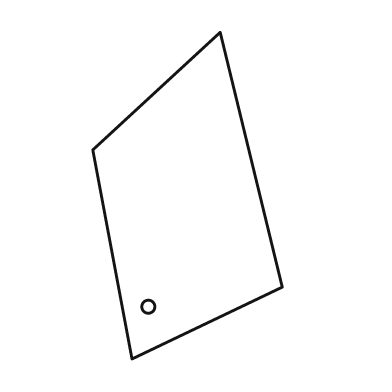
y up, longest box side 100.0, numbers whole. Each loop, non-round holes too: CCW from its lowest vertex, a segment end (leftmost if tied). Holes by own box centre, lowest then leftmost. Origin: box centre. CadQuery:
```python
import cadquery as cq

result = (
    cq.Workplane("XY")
    .moveTo(-17.0, -50.0)
    .lineTo(29.0, -28.0)
    .lineTo(10.0, 50.0)
    .lineTo(-29.0, 14.0)
    .close()
    .moveTo(-12.0, -34.0)
    .circle(2.0)
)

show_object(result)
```